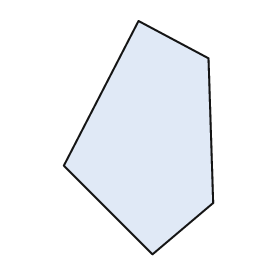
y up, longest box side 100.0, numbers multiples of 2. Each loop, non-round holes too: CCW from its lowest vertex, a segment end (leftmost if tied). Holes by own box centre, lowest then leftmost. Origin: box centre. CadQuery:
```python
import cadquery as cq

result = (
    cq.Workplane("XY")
    .moveTo(6.0, -50.0)
    .lineTo(32.0, -28.0)
    .lineTo(30.0, 34.0)
    .lineTo(0.0, 50.0)
    .lineTo(-32.0, -12.0)
    .close()
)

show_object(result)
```